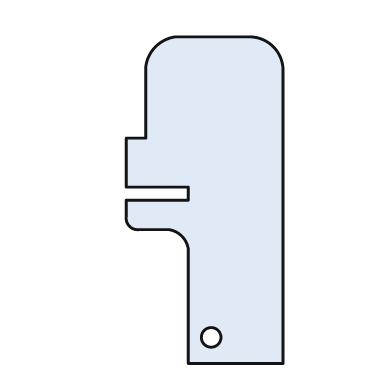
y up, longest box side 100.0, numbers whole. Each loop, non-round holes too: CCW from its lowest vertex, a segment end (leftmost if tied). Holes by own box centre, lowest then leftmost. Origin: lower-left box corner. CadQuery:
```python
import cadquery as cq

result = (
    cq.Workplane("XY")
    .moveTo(19.0, 0.0)
    .lineTo(48.0, 0.0)
    .lineTo(48.0, 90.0)
    .threePointArc((45.0, 97.0), (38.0, 100.0))
    .lineTo(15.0, 100.0)
    .threePointArc((9.0, 97.0), (6.0, 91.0))
    .lineTo(6.0, 69.0)
    .lineTo(0.0, 69.0)
    .lineTo(0.0, 54.0)
    .lineTo(19.0, 54.0)
    .lineTo(19.0, 50.0)
    .lineTo(0.0, 50.0)
    .lineTo(0.0, 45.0)
    .threePointArc((1.0, 42.0), (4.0, 41.0))
    .lineTo(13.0, 41.0)
    .threePointArc((17.0, 39.0), (19.0, 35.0))
    .close()
    .moveTo(26.0, 8.0)
    .circle(3.0)
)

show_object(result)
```